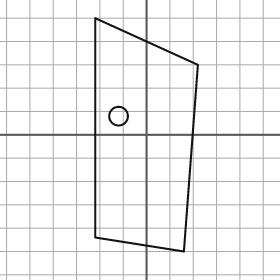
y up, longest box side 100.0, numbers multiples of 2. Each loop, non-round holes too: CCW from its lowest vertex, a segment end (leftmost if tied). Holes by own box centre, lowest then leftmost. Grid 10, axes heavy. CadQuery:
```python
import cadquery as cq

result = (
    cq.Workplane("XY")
    .moveTo(16.0, -50.0)
    .lineTo(22.0, 30.0)
    .lineTo(-22.0, 50.0)
    .lineTo(-22.0, -44.0)
    .close()
    .moveTo(-12.0, 8.0)
    .circle(4.0)
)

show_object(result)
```